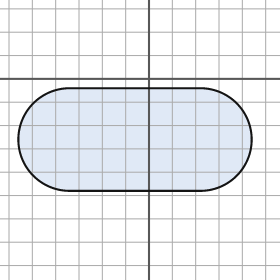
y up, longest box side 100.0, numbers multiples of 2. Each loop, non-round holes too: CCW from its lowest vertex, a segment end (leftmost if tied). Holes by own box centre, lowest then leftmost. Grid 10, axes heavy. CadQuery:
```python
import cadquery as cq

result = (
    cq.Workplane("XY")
    .moveTo(-34.0, -48.0)
    .lineTo(22.0, -48.0)
    .threePointArc((44.0, -26.0), (22.0, -4.0))
    .lineTo(-34.0, -4.0)
    .threePointArc((-56.0, -26.0), (-34.0, -48.0))
    .close()
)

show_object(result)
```